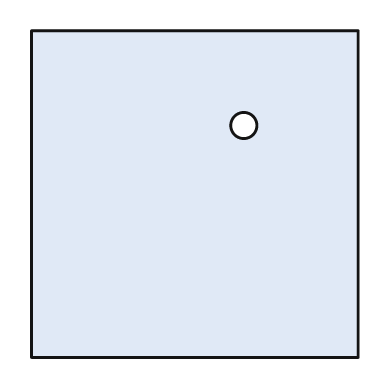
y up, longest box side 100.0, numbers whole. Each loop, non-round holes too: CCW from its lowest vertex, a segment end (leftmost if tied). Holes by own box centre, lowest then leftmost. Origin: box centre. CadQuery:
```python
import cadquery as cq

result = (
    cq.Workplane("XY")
    .moveTo(-50.0, -50.0)
    .lineTo(50.0, -50.0)
    .lineTo(50.0, 50.0)
    .lineTo(-50.0, 50.0)
    .close()
    .moveTo(15.0, 21.0)
    .circle(4.0)
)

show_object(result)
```